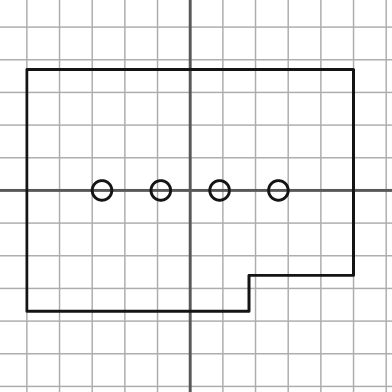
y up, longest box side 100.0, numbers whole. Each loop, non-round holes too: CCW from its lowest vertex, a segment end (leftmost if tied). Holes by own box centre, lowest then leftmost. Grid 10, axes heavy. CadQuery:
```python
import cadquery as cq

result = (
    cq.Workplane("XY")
    .moveTo(-50.0, -37.0)
    .lineTo(18.0, -37.0)
    .lineTo(18.0, -26.0)
    .lineTo(50.0, -26.0)
    .lineTo(50.0, 37.0)
    .lineTo(-50.0, 37.0)
    .close()
    .moveTo(-27.0, 0.0)
    .circle(3.0)
    .moveTo(-9.0, 0.0)
    .circle(3.0)
    .moveTo(9.0, 0.0)
    .circle(3.0)
    .moveTo(27.0, 0.0)
    .circle(3.0)
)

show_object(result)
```